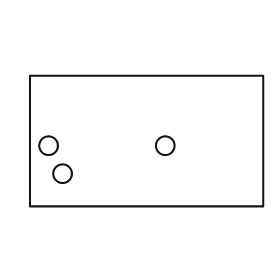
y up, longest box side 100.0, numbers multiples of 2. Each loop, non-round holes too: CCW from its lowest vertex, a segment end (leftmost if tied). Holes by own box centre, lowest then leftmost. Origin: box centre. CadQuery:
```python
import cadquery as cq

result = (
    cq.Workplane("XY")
    .moveTo(-50.0, -28.0)
    .lineTo(50.0, -28.0)
    .lineTo(50.0, 28.0)
    .lineTo(-50.0, 28.0)
    .close()
    .moveTo(-36.0, -14.0)
    .circle(4.0)
    .moveTo(-42.0, -2.0)
    .circle(4.0)
    .moveTo(8.0, -2.0)
    .circle(4.0)
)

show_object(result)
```